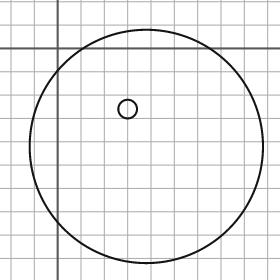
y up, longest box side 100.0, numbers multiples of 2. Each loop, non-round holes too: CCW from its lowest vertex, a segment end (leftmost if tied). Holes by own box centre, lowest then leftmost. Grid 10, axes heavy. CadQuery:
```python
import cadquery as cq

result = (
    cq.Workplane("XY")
    .moveTo(38.0, -42.0)
    .circle(50.0)
    .moveTo(30.0, -26.0)
    .circle(4.0)
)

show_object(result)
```